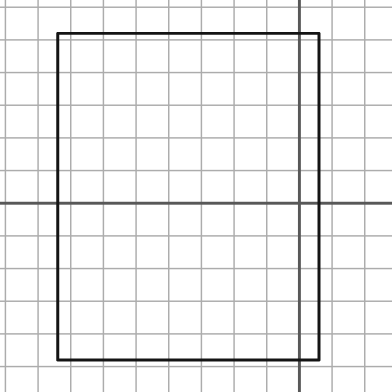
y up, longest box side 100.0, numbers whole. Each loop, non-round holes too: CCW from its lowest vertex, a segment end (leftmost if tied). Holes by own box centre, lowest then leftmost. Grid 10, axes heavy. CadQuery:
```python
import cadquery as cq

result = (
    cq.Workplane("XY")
    .moveTo(-74.0, -48.0)
    .lineTo(6.0, -48.0)
    .lineTo(6.0, 52.0)
    .lineTo(-74.0, 52.0)
    .close()
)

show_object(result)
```